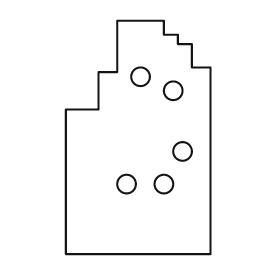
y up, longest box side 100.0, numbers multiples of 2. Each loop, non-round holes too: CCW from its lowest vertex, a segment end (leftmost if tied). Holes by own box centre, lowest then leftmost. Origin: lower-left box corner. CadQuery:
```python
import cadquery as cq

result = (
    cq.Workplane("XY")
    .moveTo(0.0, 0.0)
    .lineTo(62.0, 0.0)
    .lineTo(62.0, 80.0)
    .lineTo(54.0, 80.0)
    .lineTo(54.0, 90.0)
    .lineTo(48.0, 90.0)
    .lineTo(48.0, 94.0)
    .lineTo(42.0, 94.0)
    .lineTo(42.0, 100.0)
    .lineTo(22.0, 100.0)
    .lineTo(22.0, 78.0)
    .lineTo(14.0, 78.0)
    .lineTo(14.0, 62.0)
    .lineTo(0.0, 62.0)
    .close()
    .moveTo(26.0, 30.0)
    .circle(4.0)
    .moveTo(42.0, 30.0)
    .circle(4.0)
    .moveTo(50.0, 44.0)
    .circle(4.0)
    .moveTo(46.0, 70.0)
    .circle(4.0)
    .moveTo(32.0, 76.0)
    .circle(4.0)
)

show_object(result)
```